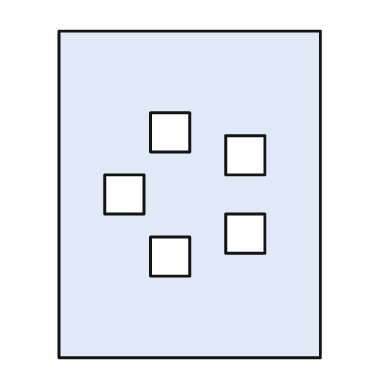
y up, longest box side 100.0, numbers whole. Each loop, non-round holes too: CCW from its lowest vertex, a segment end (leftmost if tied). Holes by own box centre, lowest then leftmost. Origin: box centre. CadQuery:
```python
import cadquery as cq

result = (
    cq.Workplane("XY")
    .moveTo(-40.0, -50.0)
    .lineTo(40.0, -50.0)
    .lineTo(40.0, 50.0)
    .lineTo(-40.0, 50.0)
    .close()
    .moveTo(-12.0, -25.0)
    .lineTo(0.0, -25.0)
    .lineTo(0.0, -13.0)
    .lineTo(-12.0, -13.0)
    .close()
    .moveTo(11.0, -18.0)
    .lineTo(23.0, -18.0)
    .lineTo(23.0, -6.0)
    .lineTo(11.0, -6.0)
    .close()
    .moveTo(-26.0, -6.0)
    .lineTo(-14.0, -6.0)
    .lineTo(-14.0, 6.0)
    .lineTo(-26.0, 6.0)
    .close()
    .moveTo(11.0, 6.0)
    .lineTo(23.0, 6.0)
    .lineTo(23.0, 18.0)
    .lineTo(11.0, 18.0)
    .close()
    .moveTo(-12.0, 13.0)
    .lineTo(0.0, 13.0)
    .lineTo(0.0, 25.0)
    .lineTo(-12.0, 25.0)
    .close()
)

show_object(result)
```